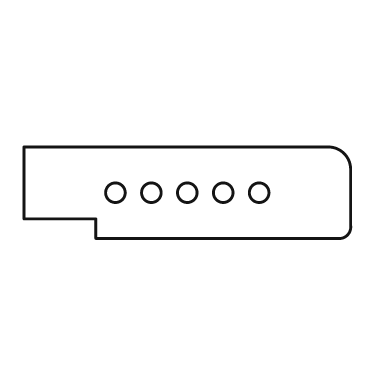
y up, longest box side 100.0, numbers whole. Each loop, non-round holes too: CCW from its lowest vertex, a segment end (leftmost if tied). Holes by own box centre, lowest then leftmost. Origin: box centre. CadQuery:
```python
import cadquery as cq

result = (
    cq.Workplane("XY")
    .moveTo(-28.0, -14.0)
    .lineTo(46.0, -14.0)
    .threePointArc((49.0, -13.0), (50.0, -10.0))
    .lineTo(50.0, 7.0)
    .threePointArc((48.0, 12.0), (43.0, 14.0))
    .lineTo(-50.0, 14.0)
    .lineTo(-50.0, -8.0)
    .lineTo(-28.0, -8.0)
    .close()
    .moveTo(-22.0, 0.0)
    .circle(3.0)
    .moveTo(-11.0, 0.0)
    .circle(3.0)
    .moveTo(0.0, 0.0)
    .circle(3.0)
    .moveTo(11.0, 0.0)
    .circle(3.0)
    .moveTo(22.0, 0.0)
    .circle(3.0)
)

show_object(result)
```